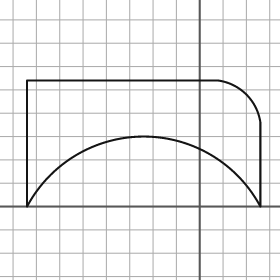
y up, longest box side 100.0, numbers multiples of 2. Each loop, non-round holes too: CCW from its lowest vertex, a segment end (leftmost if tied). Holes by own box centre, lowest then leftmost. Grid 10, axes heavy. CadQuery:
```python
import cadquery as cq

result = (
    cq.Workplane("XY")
    .moveTo(-74.0, 0.0)
    .threePointArc((-24.0, 30.0), (26.0, 0.0))
    .lineTo(26.0, 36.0)
    .threePointArc((20.0, 48.0), (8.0, 54.0))
    .lineTo(-74.0, 54.0)
    .close()
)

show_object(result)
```